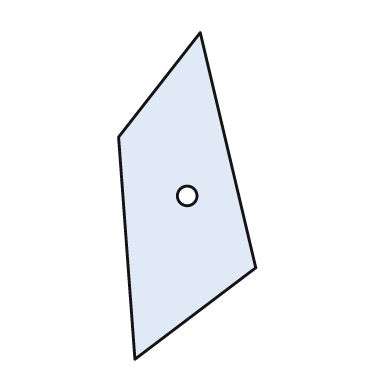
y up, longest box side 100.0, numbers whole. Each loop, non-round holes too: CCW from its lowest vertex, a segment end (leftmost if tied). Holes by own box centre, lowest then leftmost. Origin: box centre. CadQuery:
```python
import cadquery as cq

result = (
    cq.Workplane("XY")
    .moveTo(-16.0, -50.0)
    .lineTo(21.0, -22.0)
    .lineTo(4.0, 50.0)
    .lineTo(-21.0, 18.0)
    .close()
    .moveTo(0.0, 0.0)
    .circle(3.0)
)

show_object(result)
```